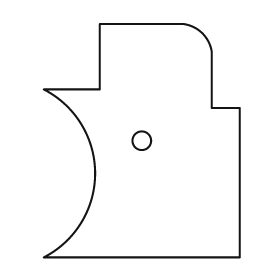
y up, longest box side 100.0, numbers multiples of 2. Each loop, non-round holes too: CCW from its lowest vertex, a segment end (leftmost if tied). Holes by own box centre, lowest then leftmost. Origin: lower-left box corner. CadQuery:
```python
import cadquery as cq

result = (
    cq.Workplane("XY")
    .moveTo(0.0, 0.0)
    .lineTo(84.0, 0.0)
    .lineTo(84.0, 64.0)
    .lineTo(72.0, 64.0)
    .lineTo(72.0, 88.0)
    .threePointArc((68.0, 96.0), (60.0, 100.0))
    .lineTo(24.0, 100.0)
    .lineTo(24.0, 72.0)
    .lineTo(0.0, 72.0)
    .threePointArc((22.0, 36.0), (0.0, 0.0))
    .close()
    .moveTo(42.0, 50.0)
    .circle(4.0)
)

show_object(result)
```